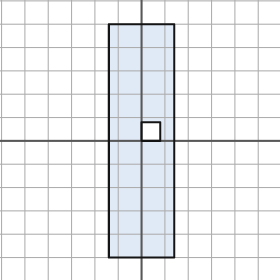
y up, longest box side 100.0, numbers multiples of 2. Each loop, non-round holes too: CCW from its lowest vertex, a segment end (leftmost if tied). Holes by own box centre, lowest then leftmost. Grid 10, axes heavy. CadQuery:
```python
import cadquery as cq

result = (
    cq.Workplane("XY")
    .moveTo(-14.0, -50.0)
    .lineTo(14.0, -50.0)
    .lineTo(14.0, 50.0)
    .lineTo(-14.0, 50.0)
    .close()
    .moveTo(0.0, 0.0)
    .lineTo(8.0, 0.0)
    .lineTo(8.0, 8.0)
    .lineTo(0.0, 8.0)
    .close()
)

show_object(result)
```